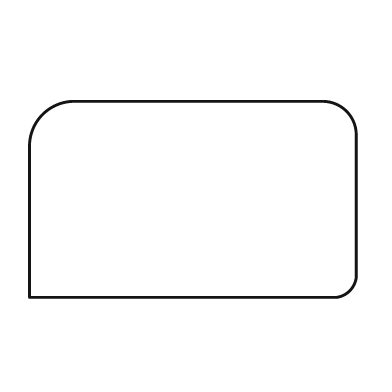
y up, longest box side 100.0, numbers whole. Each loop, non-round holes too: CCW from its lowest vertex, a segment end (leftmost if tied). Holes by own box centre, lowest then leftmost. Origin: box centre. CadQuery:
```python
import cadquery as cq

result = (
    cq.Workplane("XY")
    .moveTo(-50.0, -30.0)
    .lineTo(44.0, -30.0)
    .threePointArc((48.0, -28.0), (50.0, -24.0))
    .lineTo(50.0, 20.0)
    .threePointArc((47.0, 27.0), (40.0, 30.0))
    .lineTo(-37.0, 30.0)
    .threePointArc((-46.0, 26.0), (-50.0, 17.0))
    .close()
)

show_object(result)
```